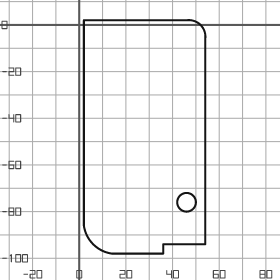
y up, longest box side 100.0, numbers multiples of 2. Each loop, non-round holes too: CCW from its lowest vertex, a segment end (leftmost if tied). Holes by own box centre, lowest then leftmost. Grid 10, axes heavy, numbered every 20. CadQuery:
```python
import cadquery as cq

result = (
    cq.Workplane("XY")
    .moveTo(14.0, -98.0)
    .lineTo(36.0, -98.0)
    .lineTo(36.0, -94.0)
    .lineTo(54.0, -94.0)
    .lineTo(54.0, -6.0)
    .threePointArc((52.0, 0.0), (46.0, 2.0))
    .lineTo(2.0, 2.0)
    .lineTo(2.0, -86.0)
    .threePointArc((6.0, -94.0), (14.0, -98.0))
    .close()
    .moveTo(46.0, -76.0)
    .circle(4.0)
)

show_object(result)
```